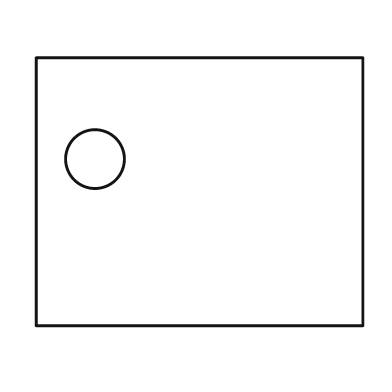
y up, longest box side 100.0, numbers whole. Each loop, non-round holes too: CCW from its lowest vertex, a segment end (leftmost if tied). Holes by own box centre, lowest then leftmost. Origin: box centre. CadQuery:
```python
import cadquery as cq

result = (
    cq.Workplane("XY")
    .moveTo(-50.0, -41.0)
    .lineTo(50.0, -41.0)
    .lineTo(50.0, 41.0)
    .lineTo(-50.0, 41.0)
    .close()
    .moveTo(-32.0, 10.0)
    .circle(9.0)
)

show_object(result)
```